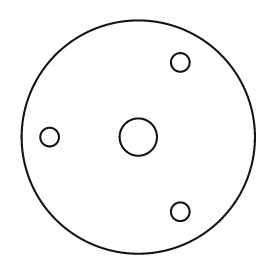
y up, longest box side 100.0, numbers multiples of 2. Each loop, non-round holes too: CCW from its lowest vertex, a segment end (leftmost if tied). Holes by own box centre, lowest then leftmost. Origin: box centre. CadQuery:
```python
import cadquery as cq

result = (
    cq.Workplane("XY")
    .moveTo(0.0, 0.0)
    .circle(50.0)
    .moveTo(18.0, -32.0)
    .circle(4.0)
    .moveTo(-38.0, 0.0)
    .circle(4.0)
    .moveTo(0.0, 0.0)
    .circle(8.0)
    .moveTo(18.0, 32.0)
    .circle(4.0)
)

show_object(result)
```